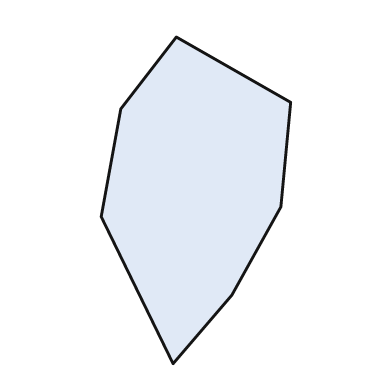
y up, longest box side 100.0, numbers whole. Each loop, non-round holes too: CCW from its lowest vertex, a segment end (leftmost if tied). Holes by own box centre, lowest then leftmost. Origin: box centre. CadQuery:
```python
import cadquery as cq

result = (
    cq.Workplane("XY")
    .moveTo(-7.0, -50.0)
    .lineTo(11.0, -29.0)
    .lineTo(26.0, -2.0)
    .lineTo(29.0, 30.0)
    .lineTo(-6.0, 50.0)
    .lineTo(-23.0, 28.0)
    .lineTo(-29.0, -5.0)
    .close()
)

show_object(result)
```